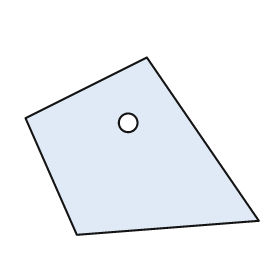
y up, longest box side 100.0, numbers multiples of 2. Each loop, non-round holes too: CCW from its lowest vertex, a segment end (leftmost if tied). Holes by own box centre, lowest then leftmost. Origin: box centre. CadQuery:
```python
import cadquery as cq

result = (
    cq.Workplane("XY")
    .moveTo(-28.0, -38.0)
    .lineTo(50.0, -32.0)
    .lineTo(2.0, 38.0)
    .lineTo(-50.0, 12.0)
    .close()
    .moveTo(-6.0, 10.0)
    .circle(4.0)
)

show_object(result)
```